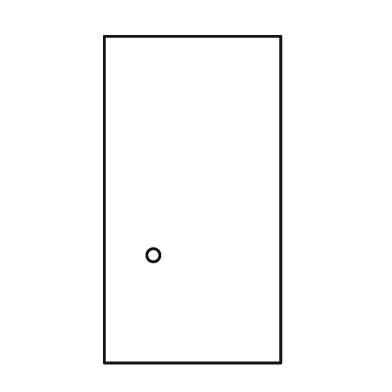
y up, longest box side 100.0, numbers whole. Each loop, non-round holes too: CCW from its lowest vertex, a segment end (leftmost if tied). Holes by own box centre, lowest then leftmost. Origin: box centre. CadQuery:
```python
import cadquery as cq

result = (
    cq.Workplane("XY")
    .moveTo(-27.0, -50.0)
    .lineTo(27.0, -50.0)
    .lineTo(27.0, 50.0)
    .lineTo(-27.0, 50.0)
    .close()
    .moveTo(-12.0, -17.0)
    .circle(2.0)
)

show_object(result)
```